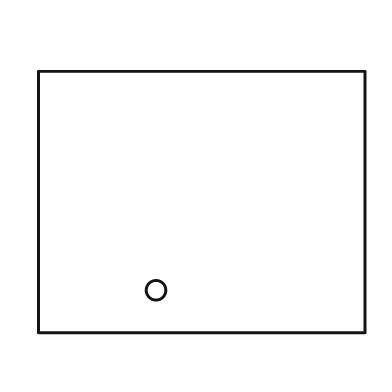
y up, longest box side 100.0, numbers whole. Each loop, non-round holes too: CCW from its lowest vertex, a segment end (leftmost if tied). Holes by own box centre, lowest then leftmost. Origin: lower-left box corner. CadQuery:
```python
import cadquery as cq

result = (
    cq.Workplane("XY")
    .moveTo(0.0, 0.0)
    .lineTo(100.0, 0.0)
    .lineTo(100.0, 80.0)
    .lineTo(0.0, 80.0)
    .close()
    .moveTo(36.0, 13.0)
    .circle(3.0)
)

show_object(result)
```